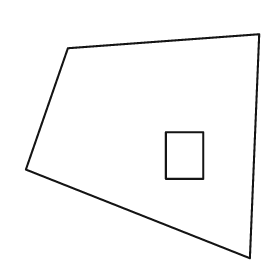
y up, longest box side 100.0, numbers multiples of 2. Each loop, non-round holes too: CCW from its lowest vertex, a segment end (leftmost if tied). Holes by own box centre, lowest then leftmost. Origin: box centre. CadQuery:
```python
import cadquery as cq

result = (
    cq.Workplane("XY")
    .moveTo(46.0, -48.0)
    .lineTo(50.0, 48.0)
    .lineTo(-32.0, 42.0)
    .lineTo(-50.0, -10.0)
    .close()
    .moveTo(10.0, -14.0)
    .lineTo(26.0, -14.0)
    .lineTo(26.0, 6.0)
    .lineTo(10.0, 6.0)
    .close()
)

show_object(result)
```